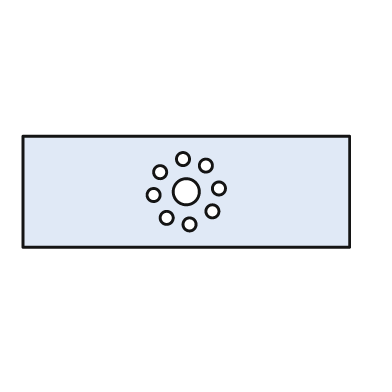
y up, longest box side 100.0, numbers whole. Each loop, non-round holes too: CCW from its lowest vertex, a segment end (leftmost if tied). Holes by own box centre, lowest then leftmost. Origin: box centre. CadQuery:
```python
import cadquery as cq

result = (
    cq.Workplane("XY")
    .moveTo(-50.0, -17.0)
    .lineTo(50.0, -17.0)
    .lineTo(50.0, 17.0)
    .lineTo(-50.0, 17.0)
    .close()
    .moveTo(1.0, -10.0)
    .circle(2.0)
    .moveTo(-6.0, -8.0)
    .circle(2.0)
    .moveTo(8.0, -6.0)
    .circle(2.0)
    .moveTo(-10.0, -1.0)
    .circle(2.0)
    .moveTo(0.0, 0.0)
    .circle(4.0)
    .moveTo(10.0, 1.0)
    .circle(2.0)
    .moveTo(-8.0, 6.0)
    .circle(2.0)
    .moveTo(6.0, 8.0)
    .circle(2.0)
    .moveTo(-1.0, 10.0)
    .circle(2.0)
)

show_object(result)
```